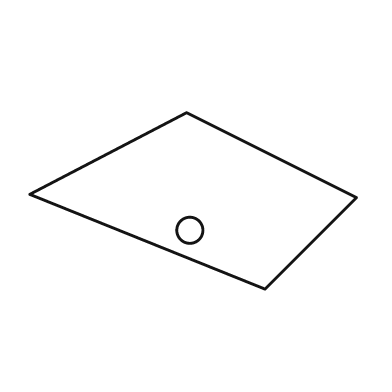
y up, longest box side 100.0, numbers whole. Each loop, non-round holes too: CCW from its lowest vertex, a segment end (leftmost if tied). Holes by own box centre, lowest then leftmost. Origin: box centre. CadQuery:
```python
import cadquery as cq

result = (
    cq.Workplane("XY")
    .moveTo(22.0, -27.0)
    .lineTo(50.0, 1.0)
    .lineTo(-2.0, 27.0)
    .lineTo(-50.0, 2.0)
    .close()
    .moveTo(-1.0, -9.0)
    .circle(4.0)
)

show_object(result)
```